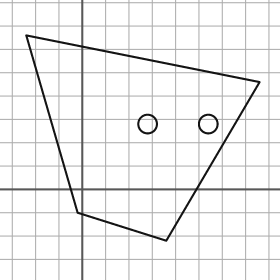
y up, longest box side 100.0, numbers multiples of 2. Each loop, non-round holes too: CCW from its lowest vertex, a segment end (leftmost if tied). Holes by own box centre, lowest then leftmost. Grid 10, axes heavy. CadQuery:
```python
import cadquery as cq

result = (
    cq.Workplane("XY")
    .moveTo(36.0, -22.0)
    .lineTo(76.0, 46.0)
    .lineTo(-24.0, 66.0)
    .lineTo(-2.0, -10.0)
    .close()
    .moveTo(28.0, 28.0)
    .circle(4.0)
    .moveTo(54.0, 28.0)
    .circle(4.0)
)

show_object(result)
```